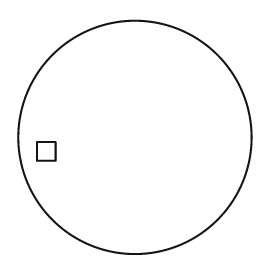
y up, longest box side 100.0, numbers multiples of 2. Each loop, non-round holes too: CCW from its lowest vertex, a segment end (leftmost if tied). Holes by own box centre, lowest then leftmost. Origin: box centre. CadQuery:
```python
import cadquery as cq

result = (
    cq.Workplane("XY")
    .moveTo(0.0, 0.0)
    .circle(50.0)
    .moveTo(-42.0, -10.0)
    .lineTo(-34.0, -10.0)
    .lineTo(-34.0, -2.0)
    .lineTo(-42.0, -2.0)
    .close()
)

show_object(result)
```